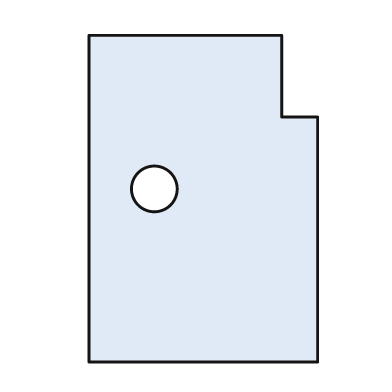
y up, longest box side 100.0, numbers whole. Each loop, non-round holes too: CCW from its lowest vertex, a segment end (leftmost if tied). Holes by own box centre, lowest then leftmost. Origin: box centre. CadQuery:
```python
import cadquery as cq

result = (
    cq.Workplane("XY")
    .moveTo(-35.0, -50.0)
    .lineTo(35.0, -50.0)
    .lineTo(35.0, 25.0)
    .lineTo(24.0, 25.0)
    .lineTo(24.0, 50.0)
    .lineTo(-35.0, 50.0)
    .close()
    .moveTo(-15.0, 3.0)
    .circle(7.0)
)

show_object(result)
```